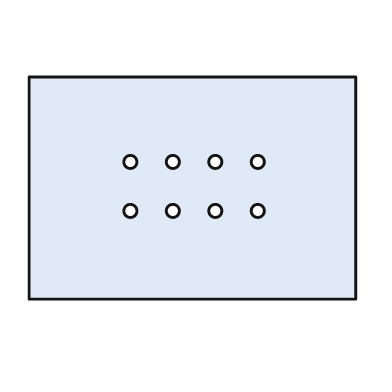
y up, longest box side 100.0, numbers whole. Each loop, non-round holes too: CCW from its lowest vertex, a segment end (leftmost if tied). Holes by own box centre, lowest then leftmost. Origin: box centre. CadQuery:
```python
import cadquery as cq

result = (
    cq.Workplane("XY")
    .moveTo(-50.0, -34.0)
    .lineTo(50.0, -34.0)
    .lineTo(50.0, 34.0)
    .lineTo(-50.0, 34.0)
    .close()
    .moveTo(-19.0, -7.0)
    .circle(2.0)
    .moveTo(-6.0, -7.0)
    .circle(2.0)
    .moveTo(7.0, -7.0)
    .circle(2.0)
    .moveTo(20.0, -7.0)
    .circle(2.0)
    .moveTo(-19.0, 8.0)
    .circle(2.0)
    .moveTo(-6.0, 8.0)
    .circle(2.0)
    .moveTo(7.0, 8.0)
    .circle(2.0)
    .moveTo(20.0, 8.0)
    .circle(2.0)
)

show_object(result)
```